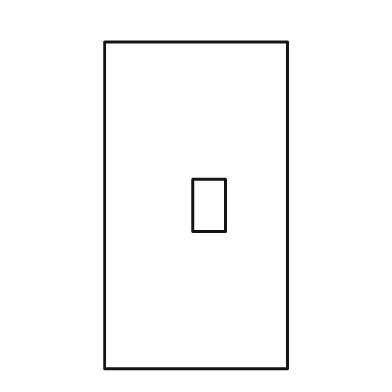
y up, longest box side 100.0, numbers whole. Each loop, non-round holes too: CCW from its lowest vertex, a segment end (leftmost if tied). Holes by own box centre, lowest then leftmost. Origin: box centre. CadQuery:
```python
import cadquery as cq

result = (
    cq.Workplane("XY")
    .moveTo(-28.0, -50.0)
    .lineTo(28.0, -50.0)
    .lineTo(28.0, 50.0)
    .lineTo(-28.0, 50.0)
    .close()
    .moveTo(-1.0, -8.0)
    .lineTo(9.0, -8.0)
    .lineTo(9.0, 8.0)
    .lineTo(-1.0, 8.0)
    .close()
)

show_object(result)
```